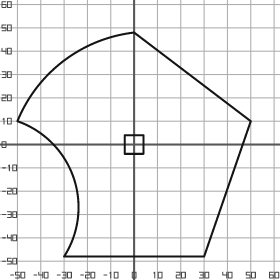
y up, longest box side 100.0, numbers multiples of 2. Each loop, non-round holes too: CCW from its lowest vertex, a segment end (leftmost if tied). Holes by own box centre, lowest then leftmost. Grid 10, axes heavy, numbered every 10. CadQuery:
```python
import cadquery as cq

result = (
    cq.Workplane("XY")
    .moveTo(-30.0, -48.0)
    .lineTo(30.0, -48.0)
    .lineTo(50.0, 10.0)
    .lineTo(0.0, 48.0)
    .threePointArc((-30.0, 36.0), (-50.0, 10.0))
    .threePointArc((-26.0, -14.0), (-30.0, -48.0))
    .close()
    .moveTo(-4.0, -4.0)
    .lineTo(4.0, -4.0)
    .lineTo(4.0, 4.0)
    .lineTo(-4.0, 4.0)
    .close()
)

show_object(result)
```